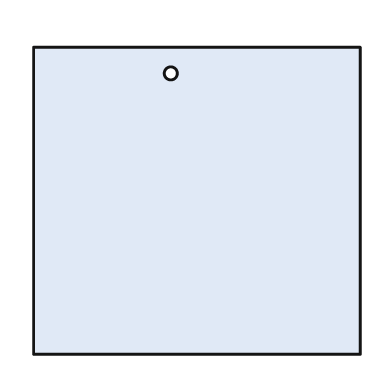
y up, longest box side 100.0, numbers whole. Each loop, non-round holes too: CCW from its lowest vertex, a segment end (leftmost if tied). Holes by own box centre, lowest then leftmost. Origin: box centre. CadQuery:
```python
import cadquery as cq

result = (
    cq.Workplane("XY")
    .moveTo(-50.0, -47.0)
    .lineTo(50.0, -47.0)
    .lineTo(50.0, 47.0)
    .lineTo(-50.0, 47.0)
    .close()
    .moveTo(-8.0, 39.0)
    .circle(2.0)
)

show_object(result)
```